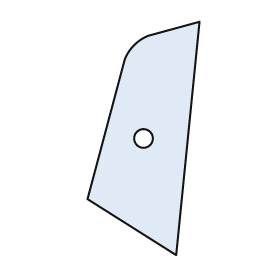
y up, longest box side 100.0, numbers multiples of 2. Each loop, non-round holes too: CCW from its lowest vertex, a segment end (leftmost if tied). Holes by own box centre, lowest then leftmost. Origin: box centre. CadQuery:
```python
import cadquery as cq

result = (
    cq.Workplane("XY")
    .moveTo(14.0, -50.0)
    .lineTo(24.0, 50.0)
    .lineTo(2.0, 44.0)
    .threePointArc((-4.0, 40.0), (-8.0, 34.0))
    .lineTo(-24.0, -26.0)
    .close()
    .moveTo(0.0, 0.0)
    .circle(4.0)
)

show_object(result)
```